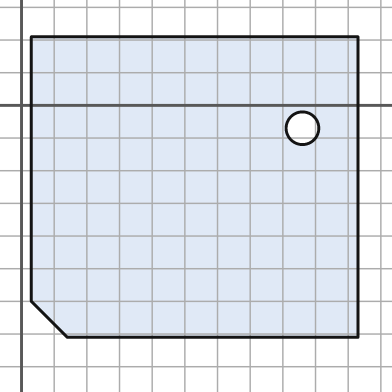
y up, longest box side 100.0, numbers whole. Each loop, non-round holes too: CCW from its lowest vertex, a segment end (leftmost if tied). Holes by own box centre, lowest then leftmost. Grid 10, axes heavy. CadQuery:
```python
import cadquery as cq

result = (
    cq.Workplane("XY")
    .moveTo(14.0, -71.0)
    .lineTo(103.0, -71.0)
    .lineTo(103.0, 21.0)
    .lineTo(3.0, 21.0)
    .lineTo(3.0, -60.0)
    .close()
    .moveTo(86.0, -7.0)
    .circle(5.0)
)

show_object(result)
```